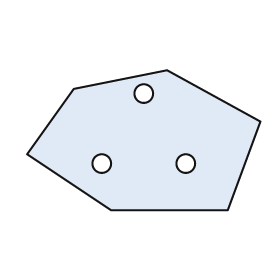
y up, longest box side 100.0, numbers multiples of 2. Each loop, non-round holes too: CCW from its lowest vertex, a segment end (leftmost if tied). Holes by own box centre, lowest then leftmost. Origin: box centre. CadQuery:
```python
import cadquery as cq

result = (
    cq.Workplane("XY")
    .moveTo(-14.0, -30.0)
    .lineTo(36.0, -30.0)
    .lineTo(50.0, 8.0)
    .lineTo(10.0, 30.0)
    .lineTo(-30.0, 22.0)
    .lineTo(-50.0, -6.0)
    .close()
    .moveTo(-18.0, -10.0)
    .circle(4.0)
    .moveTo(18.0, -10.0)
    .circle(4.0)
    .moveTo(0.0, 20.0)
    .circle(4.0)
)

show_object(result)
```